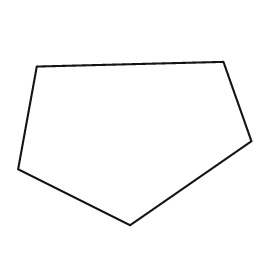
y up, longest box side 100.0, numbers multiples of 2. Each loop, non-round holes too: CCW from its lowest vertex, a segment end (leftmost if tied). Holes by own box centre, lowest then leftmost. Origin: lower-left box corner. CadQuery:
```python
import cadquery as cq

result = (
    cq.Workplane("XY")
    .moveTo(48.0, 0.0)
    .lineTo(100.0, 36.0)
    .lineTo(88.0, 70.0)
    .lineTo(8.0, 68.0)
    .lineTo(0.0, 24.0)
    .close()
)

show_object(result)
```